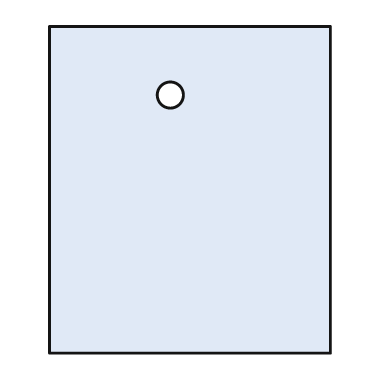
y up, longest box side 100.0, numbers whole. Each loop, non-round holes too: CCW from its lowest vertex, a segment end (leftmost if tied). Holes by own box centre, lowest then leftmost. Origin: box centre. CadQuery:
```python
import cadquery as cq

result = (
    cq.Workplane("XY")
    .moveTo(-43.0, -50.0)
    .lineTo(43.0, -50.0)
    .lineTo(43.0, 50.0)
    .lineTo(-43.0, 50.0)
    .close()
    .moveTo(-6.0, 29.0)
    .circle(4.0)
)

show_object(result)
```